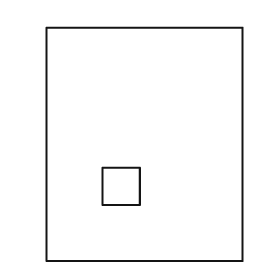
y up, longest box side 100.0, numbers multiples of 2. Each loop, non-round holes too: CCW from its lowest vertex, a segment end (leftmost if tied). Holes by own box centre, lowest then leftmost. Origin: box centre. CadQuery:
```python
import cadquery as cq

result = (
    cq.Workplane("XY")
    .moveTo(-42.0, -50.0)
    .lineTo(42.0, -50.0)
    .lineTo(42.0, 50.0)
    .lineTo(-42.0, 50.0)
    .close()
    .moveTo(-18.0, -26.0)
    .lineTo(-2.0, -26.0)
    .lineTo(-2.0, -10.0)
    .lineTo(-18.0, -10.0)
    .close()
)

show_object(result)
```